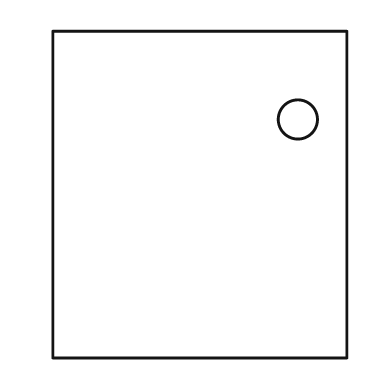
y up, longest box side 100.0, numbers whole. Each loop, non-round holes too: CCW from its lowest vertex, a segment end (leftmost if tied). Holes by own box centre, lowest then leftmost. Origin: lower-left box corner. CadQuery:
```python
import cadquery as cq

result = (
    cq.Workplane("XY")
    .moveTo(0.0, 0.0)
    .lineTo(90.0, 0.0)
    .lineTo(90.0, 100.0)
    .lineTo(0.0, 100.0)
    .close()
    .moveTo(75.0, 73.0)
    .circle(6.0)
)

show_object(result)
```